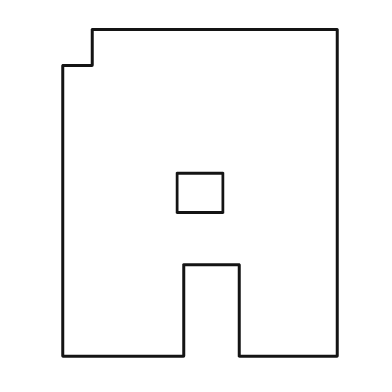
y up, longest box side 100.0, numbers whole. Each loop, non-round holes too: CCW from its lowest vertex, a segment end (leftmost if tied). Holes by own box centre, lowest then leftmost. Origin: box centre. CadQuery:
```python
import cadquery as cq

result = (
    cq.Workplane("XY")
    .moveTo(-42.0, -50.0)
    .lineTo(-5.0, -50.0)
    .lineTo(-5.0, -22.0)
    .lineTo(12.0, -22.0)
    .lineTo(12.0, -50.0)
    .lineTo(42.0, -50.0)
    .lineTo(42.0, 50.0)
    .lineTo(-33.0, 50.0)
    .lineTo(-33.0, 39.0)
    .lineTo(-42.0, 39.0)
    .close()
    .moveTo(-7.0, -6.0)
    .lineTo(7.0, -6.0)
    .lineTo(7.0, 6.0)
    .lineTo(-7.0, 6.0)
    .close()
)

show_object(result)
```